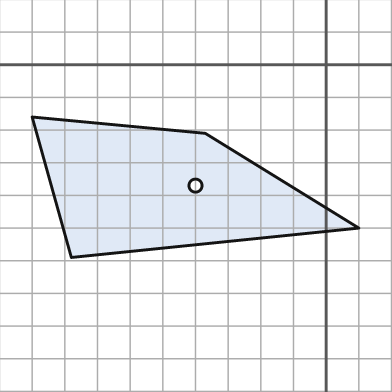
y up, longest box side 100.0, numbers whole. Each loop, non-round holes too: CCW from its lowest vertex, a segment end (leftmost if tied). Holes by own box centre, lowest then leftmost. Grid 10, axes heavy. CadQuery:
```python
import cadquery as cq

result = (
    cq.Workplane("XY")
    .moveTo(-78.0, -59.0)
    .lineTo(10.0, -50.0)
    .lineTo(-37.0, -21.0)
    .lineTo(-90.0, -16.0)
    .close()
    .moveTo(-40.0, -37.0)
    .circle(2.0)
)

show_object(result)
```